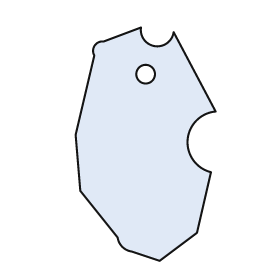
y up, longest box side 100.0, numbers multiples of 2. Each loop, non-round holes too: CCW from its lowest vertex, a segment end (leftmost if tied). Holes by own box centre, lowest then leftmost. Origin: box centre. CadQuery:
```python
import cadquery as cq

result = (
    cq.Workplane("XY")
    .moveTo(6.0, -50.0)
    .lineTo(22.0, -38.0)
    .lineTo(28.0, -12.0)
    .threePointArc((18.0, 2.0), (30.0, 14.0))
    .lineTo(12.0, 48.0)
    .threePointArc((4.0, 42.0), (-2.0, 50.0))
    .lineTo(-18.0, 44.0)
    .threePointArc((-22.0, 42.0), (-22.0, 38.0))
    .lineTo(-30.0, 4.0)
    .lineTo(-28.0, -20.0)
    .lineTo(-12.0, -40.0)
    .threePointArc((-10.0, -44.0), (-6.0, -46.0))
    .close()
    .moveTo(0.0, 30.0)
    .circle(4.0)
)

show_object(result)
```